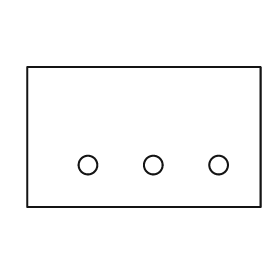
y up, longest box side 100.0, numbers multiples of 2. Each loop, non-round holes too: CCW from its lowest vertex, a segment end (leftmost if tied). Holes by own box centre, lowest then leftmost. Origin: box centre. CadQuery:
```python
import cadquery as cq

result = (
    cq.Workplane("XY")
    .moveTo(-50.0, -30.0)
    .lineTo(50.0, -30.0)
    .lineTo(50.0, 30.0)
    .lineTo(-50.0, 30.0)
    .close()
    .moveTo(-24.0, -12.0)
    .circle(4.0)
    .moveTo(4.0, -12.0)
    .circle(4.0)
    .moveTo(32.0, -12.0)
    .circle(4.0)
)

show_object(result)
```